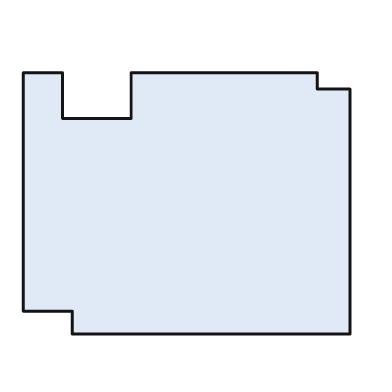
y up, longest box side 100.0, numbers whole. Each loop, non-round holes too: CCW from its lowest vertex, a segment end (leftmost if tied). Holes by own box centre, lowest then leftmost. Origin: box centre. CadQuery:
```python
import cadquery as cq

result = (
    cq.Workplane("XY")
    .moveTo(-35.0, -40.0)
    .lineTo(50.0, -40.0)
    .lineTo(50.0, 35.0)
    .lineTo(40.0, 35.0)
    .lineTo(40.0, 40.0)
    .lineTo(-17.0, 40.0)
    .lineTo(-17.0, 26.0)
    .lineTo(-38.0, 26.0)
    .lineTo(-38.0, 40.0)
    .lineTo(-50.0, 40.0)
    .lineTo(-50.0, -33.0)
    .lineTo(-35.0, -33.0)
    .close()
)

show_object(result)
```